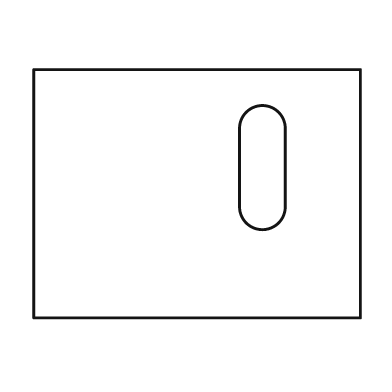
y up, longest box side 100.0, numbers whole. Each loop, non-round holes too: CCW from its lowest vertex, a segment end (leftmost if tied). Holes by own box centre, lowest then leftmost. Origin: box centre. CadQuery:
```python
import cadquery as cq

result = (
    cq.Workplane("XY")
    .moveTo(-50.0, -38.0)
    .lineTo(50.0, -38.0)
    .lineTo(50.0, 38.0)
    .lineTo(-50.0, 38.0)
    .close()
    .moveTo(13.0, -4.0)
    .threePointArc((20.0, -11.0), (27.0, -4.0))
    .lineTo(27.0, 20.0)
    .threePointArc((20.0, 27.0), (13.0, 20.0))
    .close()
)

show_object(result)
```